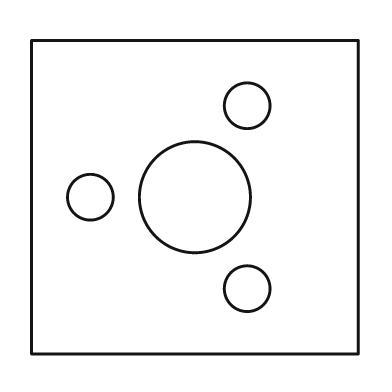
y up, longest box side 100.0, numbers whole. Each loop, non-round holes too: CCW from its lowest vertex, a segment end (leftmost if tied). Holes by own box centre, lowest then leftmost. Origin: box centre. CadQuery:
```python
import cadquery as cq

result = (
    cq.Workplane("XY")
    .moveTo(-50.0, -48.0)
    .lineTo(50.0, -48.0)
    .lineTo(50.0, 48.0)
    .lineTo(-50.0, 48.0)
    .close()
    .moveTo(16.0, -28.0)
    .circle(7.0)
    .moveTo(-32.0, 0.0)
    .circle(7.0)
    .moveTo(0.0, 0.0)
    .circle(17.0)
    .moveTo(16.0, 28.0)
    .circle(7.0)
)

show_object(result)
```